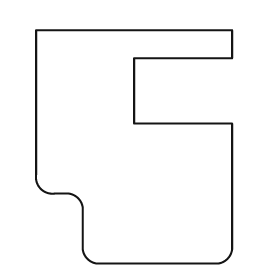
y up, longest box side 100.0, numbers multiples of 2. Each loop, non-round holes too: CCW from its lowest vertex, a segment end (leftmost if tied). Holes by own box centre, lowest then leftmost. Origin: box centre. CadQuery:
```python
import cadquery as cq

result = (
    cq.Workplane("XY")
    .moveTo(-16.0, -50.0)
    .lineTo(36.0, -50.0)
    .threePointArc((40.0, -48.0), (42.0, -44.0))
    .lineTo(42.0, 10.0)
    .lineTo(0.0, 10.0)
    .lineTo(0.0, 38.0)
    .lineTo(42.0, 38.0)
    .lineTo(42.0, 50.0)
    .lineTo(-42.0, 50.0)
    .lineTo(-42.0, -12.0)
    .threePointArc((-40.0, -18.0), (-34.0, -20.0))
    .lineTo(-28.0, -20.0)
    .threePointArc((-24.0, -22.0), (-22.0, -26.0))
    .lineTo(-22.0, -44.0)
    .threePointArc((-20.0, -48.0), (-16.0, -50.0))
    .close()
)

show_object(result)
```